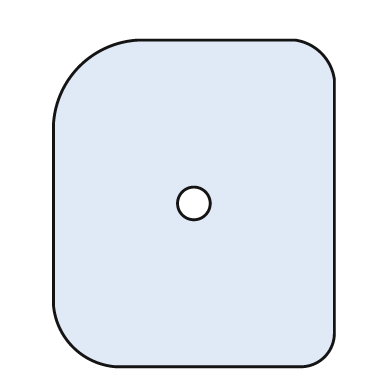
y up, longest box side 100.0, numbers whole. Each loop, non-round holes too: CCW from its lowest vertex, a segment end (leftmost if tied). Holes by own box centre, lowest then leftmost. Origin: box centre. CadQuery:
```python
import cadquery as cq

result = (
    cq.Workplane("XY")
    .moveTo(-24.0, -50.0)
    .lineTo(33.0, -50.0)
    .threePointArc((40.0, -47.0), (43.0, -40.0))
    .lineTo(43.0, 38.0)
    .threePointArc((39.0, 46.0), (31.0, 50.0))
    .lineTo(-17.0, 50.0)
    .threePointArc((-35.0, 42.0), (-43.0, 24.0))
    .lineTo(-43.0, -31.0)
    .threePointArc((-37.0, -44.0), (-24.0, -50.0))
    .close()
    .moveTo(0.0, 0.0)
    .circle(5.0)
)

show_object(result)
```